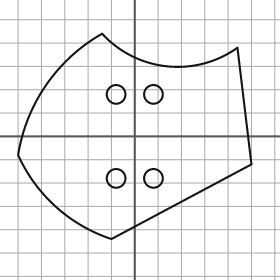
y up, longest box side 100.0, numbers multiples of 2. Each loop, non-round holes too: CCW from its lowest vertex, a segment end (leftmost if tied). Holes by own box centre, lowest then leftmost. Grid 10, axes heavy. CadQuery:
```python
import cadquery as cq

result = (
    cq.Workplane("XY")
    .moveTo(-10.0, -44.0)
    .lineTo(50.0, -12.0)
    .lineTo(44.0, 38.0)
    .threePointArc((14.0, 30.0), (-14.0, 44.0))
    .threePointArc((-38.0, 22.0), (-50.0, -8.0))
    .threePointArc((-34.0, -30.0), (-10.0, -44.0))
    .close()
    .moveTo(-8.0, -18.0)
    .circle(4.0)
    .moveTo(8.0, -18.0)
    .circle(4.0)
    .moveTo(-8.0, 18.0)
    .circle(4.0)
    .moveTo(8.0, 18.0)
    .circle(4.0)
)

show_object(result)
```